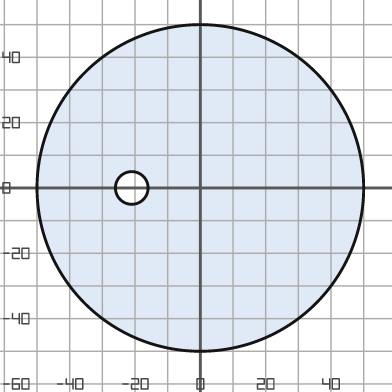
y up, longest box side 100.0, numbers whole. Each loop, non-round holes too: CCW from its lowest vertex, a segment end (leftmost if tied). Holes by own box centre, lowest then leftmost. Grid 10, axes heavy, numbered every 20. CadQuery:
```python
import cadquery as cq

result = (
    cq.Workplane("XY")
    .moveTo(0.0, 0.0)
    .circle(50.0)
    .moveTo(-21.0, 0.0)
    .circle(5.0)
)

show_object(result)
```